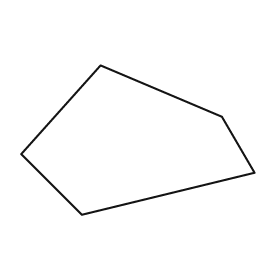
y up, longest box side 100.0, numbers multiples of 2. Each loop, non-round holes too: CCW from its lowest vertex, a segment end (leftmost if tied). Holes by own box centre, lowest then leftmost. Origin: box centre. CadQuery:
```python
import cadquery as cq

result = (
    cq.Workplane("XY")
    .moveTo(-24.0, -32.0)
    .lineTo(50.0, -14.0)
    .lineTo(36.0, 10.0)
    .lineTo(-16.0, 32.0)
    .lineTo(-50.0, -6.0)
    .close()
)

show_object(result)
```